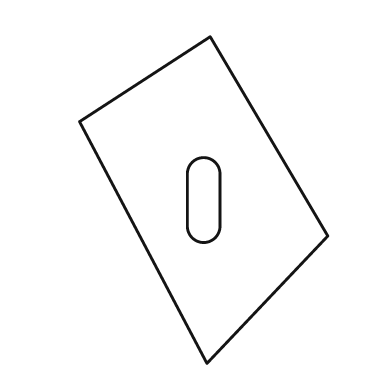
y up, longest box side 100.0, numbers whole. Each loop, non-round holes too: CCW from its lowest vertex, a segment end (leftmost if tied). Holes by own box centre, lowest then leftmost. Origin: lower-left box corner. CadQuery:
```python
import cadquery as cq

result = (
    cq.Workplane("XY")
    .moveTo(39.0, 0.0)
    .lineTo(76.0, 39.0)
    .lineTo(40.0, 100.0)
    .lineTo(0.0, 74.0)
    .close()
    .moveTo(33.0, 42.0)
    .threePointArc((38.0, 37.0), (43.0, 42.0))
    .lineTo(43.0, 58.0)
    .threePointArc((38.0, 63.0), (33.0, 58.0))
    .close()
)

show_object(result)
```